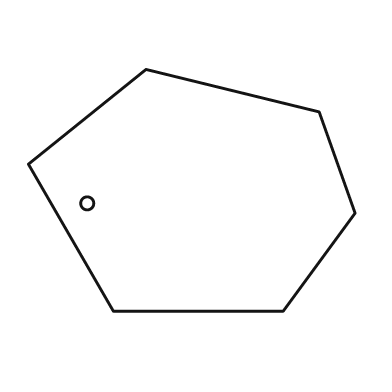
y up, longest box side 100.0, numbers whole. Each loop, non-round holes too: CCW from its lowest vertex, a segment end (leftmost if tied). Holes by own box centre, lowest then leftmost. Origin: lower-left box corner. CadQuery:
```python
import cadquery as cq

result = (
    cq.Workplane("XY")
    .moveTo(26.0, 0.0)
    .lineTo(78.0, 0.0)
    .lineTo(100.0, 30.0)
    .lineTo(89.0, 61.0)
    .lineTo(36.0, 74.0)
    .lineTo(0.0, 45.0)
    .close()
    .moveTo(18.0, 33.0)
    .circle(2.0)
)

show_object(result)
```